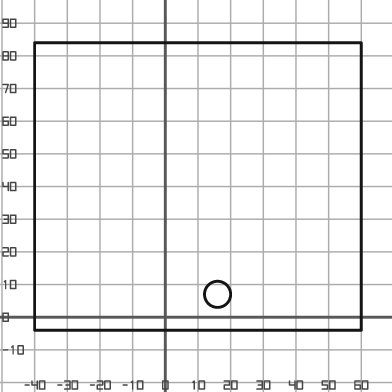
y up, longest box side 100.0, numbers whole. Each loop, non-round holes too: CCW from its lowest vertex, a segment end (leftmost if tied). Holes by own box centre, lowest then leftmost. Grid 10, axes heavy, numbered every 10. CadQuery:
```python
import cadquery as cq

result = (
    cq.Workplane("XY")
    .moveTo(-40.0, -4.0)
    .lineTo(60.0, -4.0)
    .lineTo(60.0, 84.0)
    .lineTo(-40.0, 84.0)
    .close()
    .moveTo(16.0, 7.0)
    .circle(4.0)
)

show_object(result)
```